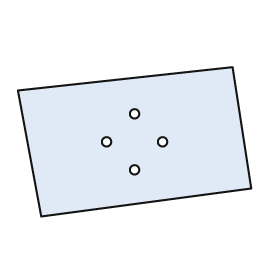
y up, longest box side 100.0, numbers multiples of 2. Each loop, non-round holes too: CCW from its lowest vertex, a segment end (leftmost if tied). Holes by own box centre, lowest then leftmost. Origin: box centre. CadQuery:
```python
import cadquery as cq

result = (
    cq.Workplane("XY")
    .moveTo(-40.0, -32.0)
    .lineTo(50.0, -20.0)
    .lineTo(42.0, 32.0)
    .lineTo(-50.0, 22.0)
    .close()
    .moveTo(0.0, -12.0)
    .circle(2.0)
    .moveTo(-12.0, 0.0)
    .circle(2.0)
    .moveTo(12.0, 0.0)
    .circle(2.0)
    .moveTo(0.0, 12.0)
    .circle(2.0)
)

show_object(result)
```